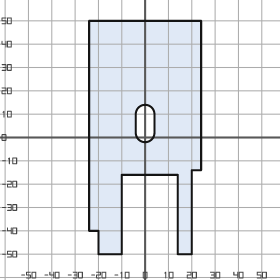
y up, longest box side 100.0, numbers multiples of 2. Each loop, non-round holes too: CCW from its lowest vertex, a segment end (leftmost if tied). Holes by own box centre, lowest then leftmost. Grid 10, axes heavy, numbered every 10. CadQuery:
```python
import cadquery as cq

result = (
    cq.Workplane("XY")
    .moveTo(-20.0, -50.0)
    .lineTo(-10.0, -50.0)
    .lineTo(-10.0, -16.0)
    .lineTo(14.0, -16.0)
    .lineTo(14.0, -50.0)
    .lineTo(20.0, -50.0)
    .lineTo(20.0, -14.0)
    .lineTo(24.0, -14.0)
    .lineTo(24.0, 50.0)
    .lineTo(-24.0, 50.0)
    .lineTo(-24.0, -40.0)
    .lineTo(-20.0, -40.0)
    .close()
    .moveTo(-4.0, 2.0)
    .threePointArc((0.0, -2.0), (4.0, 2.0))
    .lineTo(4.0, 10.0)
    .threePointArc((0.0, 14.0), (-4.0, 10.0))
    .close()
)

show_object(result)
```